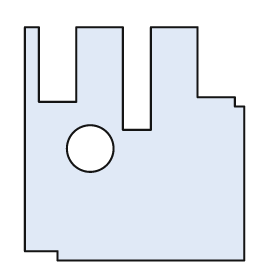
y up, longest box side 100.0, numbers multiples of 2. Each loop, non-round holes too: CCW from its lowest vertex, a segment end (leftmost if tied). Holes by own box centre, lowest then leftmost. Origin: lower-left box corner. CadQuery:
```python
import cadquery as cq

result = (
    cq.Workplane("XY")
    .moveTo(14.0, 0.0)
    .lineTo(94.0, 0.0)
    .lineTo(94.0, 66.0)
    .lineTo(90.0, 66.0)
    .lineTo(90.0, 70.0)
    .lineTo(74.0, 70.0)
    .lineTo(74.0, 100.0)
    .lineTo(54.0, 100.0)
    .lineTo(54.0, 56.0)
    .lineTo(42.0, 56.0)
    .lineTo(42.0, 100.0)
    .lineTo(22.0, 100.0)
    .lineTo(22.0, 68.0)
    .lineTo(6.0, 68.0)
    .lineTo(6.0, 100.0)
    .lineTo(0.0, 100.0)
    .lineTo(0.0, 4.0)
    .lineTo(14.0, 4.0)
    .close()
    .moveTo(28.0, 48.0)
    .circle(10.0)
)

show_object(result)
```